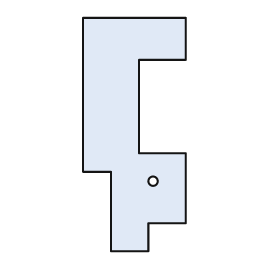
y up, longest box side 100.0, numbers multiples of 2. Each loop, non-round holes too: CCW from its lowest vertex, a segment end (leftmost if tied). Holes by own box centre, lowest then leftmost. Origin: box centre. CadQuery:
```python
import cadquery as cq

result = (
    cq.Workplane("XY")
    .moveTo(-10.0, -50.0)
    .lineTo(6.0, -50.0)
    .lineTo(6.0, -38.0)
    .lineTo(22.0, -38.0)
    .lineTo(22.0, -8.0)
    .lineTo(2.0, -8.0)
    .lineTo(2.0, 32.0)
    .lineTo(22.0, 32.0)
    .lineTo(22.0, 50.0)
    .lineTo(-22.0, 50.0)
    .lineTo(-22.0, -16.0)
    .lineTo(-10.0, -16.0)
    .close()
    .moveTo(8.0, -20.0)
    .circle(2.0)
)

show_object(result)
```